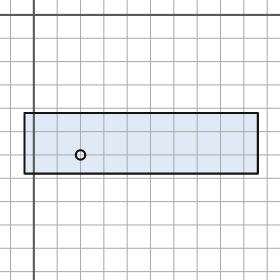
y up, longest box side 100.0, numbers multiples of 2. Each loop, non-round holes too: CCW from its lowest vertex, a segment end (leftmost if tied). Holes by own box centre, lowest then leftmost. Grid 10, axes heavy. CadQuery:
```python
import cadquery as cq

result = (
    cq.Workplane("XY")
    .moveTo(-4.0, -68.0)
    .lineTo(96.0, -68.0)
    .lineTo(96.0, -42.0)
    .lineTo(-4.0, -42.0)
    .close()
    .moveTo(20.0, -60.0)
    .circle(2.0)
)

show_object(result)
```